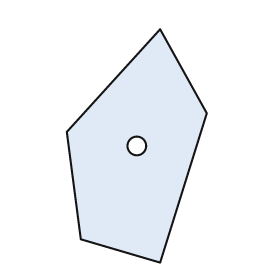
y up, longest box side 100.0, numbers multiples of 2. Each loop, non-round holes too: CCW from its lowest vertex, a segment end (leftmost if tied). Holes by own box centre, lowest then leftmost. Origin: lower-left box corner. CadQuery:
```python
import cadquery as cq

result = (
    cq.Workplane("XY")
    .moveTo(40.0, 0.0)
    .lineTo(60.0, 64.0)
    .lineTo(40.0, 100.0)
    .lineTo(0.0, 56.0)
    .lineTo(6.0, 10.0)
    .close()
    .moveTo(30.0, 50.0)
    .circle(4.0)
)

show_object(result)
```